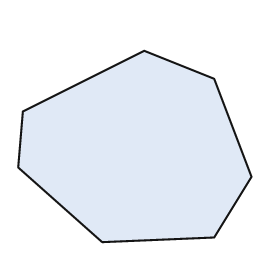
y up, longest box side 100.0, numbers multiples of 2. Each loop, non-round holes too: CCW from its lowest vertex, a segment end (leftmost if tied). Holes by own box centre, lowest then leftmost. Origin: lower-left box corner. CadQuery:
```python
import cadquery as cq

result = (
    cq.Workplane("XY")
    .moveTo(36.0, 0.0)
    .lineTo(84.0, 2.0)
    .lineTo(100.0, 28.0)
    .lineTo(84.0, 70.0)
    .lineTo(54.0, 82.0)
    .lineTo(2.0, 56.0)
    .lineTo(0.0, 32.0)
    .close()
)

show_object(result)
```